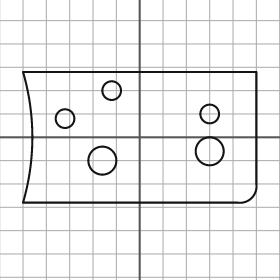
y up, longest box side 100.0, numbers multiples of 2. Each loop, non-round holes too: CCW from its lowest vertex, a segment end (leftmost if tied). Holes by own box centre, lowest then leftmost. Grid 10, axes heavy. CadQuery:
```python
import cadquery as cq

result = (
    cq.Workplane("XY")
    .moveTo(-50.0, -28.0)
    .lineTo(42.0, -28.0)
    .threePointArc((48.0, -26.0), (50.0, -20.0))
    .lineTo(50.0, 28.0)
    .lineTo(-50.0, 28.0)
    .threePointArc((-46.0, 0.0), (-50.0, -28.0))
    .close()
    .moveTo(-16.0, -10.0)
    .circle(6.0)
    .moveTo(30.0, -6.0)
    .circle(6.0)
    .moveTo(-32.0, 8.0)
    .circle(4.0)
    .moveTo(30.0, 10.0)
    .circle(4.0)
    .moveTo(-12.0, 20.0)
    .circle(4.0)
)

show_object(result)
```